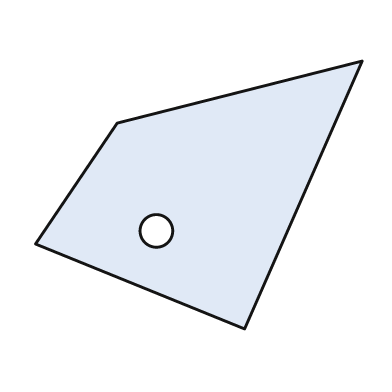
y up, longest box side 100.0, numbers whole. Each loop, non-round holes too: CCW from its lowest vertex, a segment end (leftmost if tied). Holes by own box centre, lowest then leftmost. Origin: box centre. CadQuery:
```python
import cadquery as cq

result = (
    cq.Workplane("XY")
    .moveTo(14.0, -41.0)
    .lineTo(50.0, 41.0)
    .lineTo(-25.0, 22.0)
    .lineTo(-50.0, -15.0)
    .close()
    .moveTo(-13.0, -11.0)
    .circle(5.0)
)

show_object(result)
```